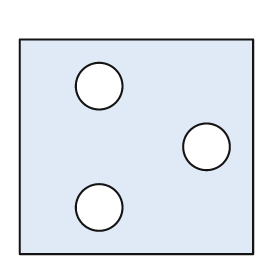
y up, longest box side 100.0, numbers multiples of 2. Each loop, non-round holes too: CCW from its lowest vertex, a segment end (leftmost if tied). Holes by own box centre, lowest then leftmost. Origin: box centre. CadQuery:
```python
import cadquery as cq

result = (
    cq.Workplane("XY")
    .moveTo(-50.0, -46.0)
    .lineTo(50.0, -46.0)
    .lineTo(50.0, 46.0)
    .lineTo(-50.0, 46.0)
    .close()
    .moveTo(-16.0, -26.0)
    .circle(10.0)
    .moveTo(30.0, 0.0)
    .circle(10.0)
    .moveTo(-16.0, 26.0)
    .circle(10.0)
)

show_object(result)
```